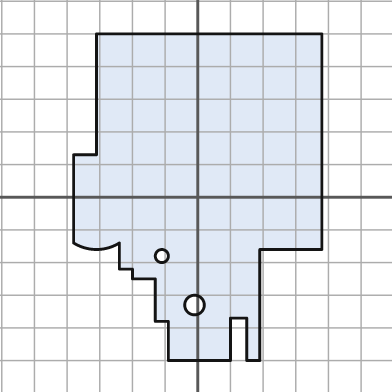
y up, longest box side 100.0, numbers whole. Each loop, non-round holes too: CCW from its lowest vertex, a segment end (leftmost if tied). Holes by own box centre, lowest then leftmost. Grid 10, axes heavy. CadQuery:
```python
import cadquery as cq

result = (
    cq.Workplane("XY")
    .moveTo(-9.0, -50.0)
    .lineTo(10.0, -50.0)
    .lineTo(10.0, -37.0)
    .lineTo(15.0, -37.0)
    .lineTo(15.0, -50.0)
    .lineTo(19.0, -50.0)
    .lineTo(19.0, -16.0)
    .lineTo(38.0, -16.0)
    .lineTo(38.0, 50.0)
    .lineTo(-31.0, 50.0)
    .lineTo(-31.0, 13.0)
    .lineTo(-38.0, 13.0)
    .lineTo(-38.0, -14.0)
    .threePointArc((-31.0, -16.0), (-24.0, -14.0))
    .lineTo(-24.0, -22.0)
    .lineTo(-20.0, -22.0)
    .lineTo(-20.0, -25.0)
    .lineTo(-13.0, -25.0)
    .lineTo(-13.0, -38.0)
    .lineTo(-9.0, -38.0)
    .close()
    .moveTo(-1.0, -33.0)
    .circle(3.0)
    .moveTo(-11.0, -18.0)
    .circle(2.0)
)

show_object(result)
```